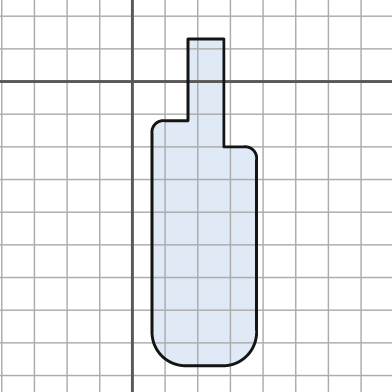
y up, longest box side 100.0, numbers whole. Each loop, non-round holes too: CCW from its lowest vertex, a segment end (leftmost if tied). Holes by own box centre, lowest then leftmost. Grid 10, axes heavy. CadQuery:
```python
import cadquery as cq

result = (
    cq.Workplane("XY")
    .moveTo(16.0, -87.0)
    .lineTo(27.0, -87.0)
    .threePointArc((35.0, -84.0), (38.0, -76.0))
    .lineTo(38.0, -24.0)
    .threePointArc((37.0, -21.0), (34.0, -20.0))
    .lineTo(28.0, -20.0)
    .lineTo(28.0, 13.0)
    .lineTo(17.0, 13.0)
    .lineTo(17.0, -12.0)
    .lineTo(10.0, -12.0)
    .threePointArc((7.0, -13.0), (6.0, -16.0))
    .lineTo(6.0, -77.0)
    .threePointArc((9.0, -84.0), (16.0, -87.0))
    .close()
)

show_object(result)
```